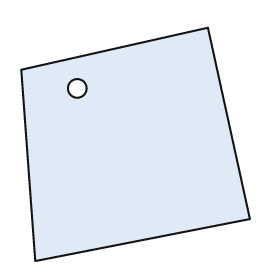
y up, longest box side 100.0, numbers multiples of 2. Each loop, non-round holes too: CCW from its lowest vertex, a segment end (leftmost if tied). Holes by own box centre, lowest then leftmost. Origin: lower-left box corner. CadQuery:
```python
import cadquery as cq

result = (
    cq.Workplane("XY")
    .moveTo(6.0, 0.0)
    .lineTo(98.0, 18.0)
    .lineTo(80.0, 100.0)
    .lineTo(0.0, 82.0)
    .close()
    .moveTo(24.0, 74.0)
    .circle(4.0)
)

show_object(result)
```